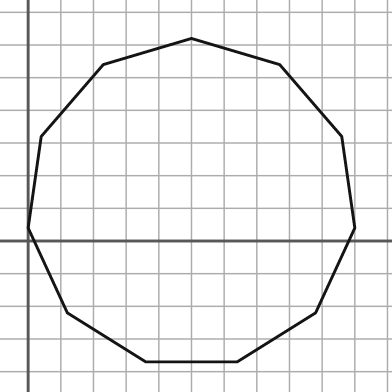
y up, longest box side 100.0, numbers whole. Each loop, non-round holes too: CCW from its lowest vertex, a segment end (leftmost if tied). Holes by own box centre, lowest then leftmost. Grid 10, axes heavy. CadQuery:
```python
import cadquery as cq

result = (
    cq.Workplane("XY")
    .moveTo(36.0, -37.0)
    .lineTo(64.0, -37.0)
    .lineTo(88.0, -22.0)
    .lineTo(100.0, 4.0)
    .lineTo(96.0, 32.0)
    .lineTo(77.0, 54.0)
    .lineTo(50.0, 62.0)
    .lineTo(23.0, 54.0)
    .lineTo(4.0, 32.0)
    .lineTo(0.0, 4.0)
    .lineTo(12.0, -22.0)
    .close()
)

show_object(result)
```